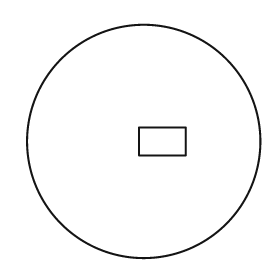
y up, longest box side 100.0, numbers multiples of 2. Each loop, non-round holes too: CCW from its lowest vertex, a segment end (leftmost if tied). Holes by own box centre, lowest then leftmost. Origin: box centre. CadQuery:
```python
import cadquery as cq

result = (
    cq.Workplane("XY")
    .moveTo(0.0, 0.0)
    .circle(50.0)
    .moveTo(-2.0, -6.0)
    .lineTo(18.0, -6.0)
    .lineTo(18.0, 6.0)
    .lineTo(-2.0, 6.0)
    .close()
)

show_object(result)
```